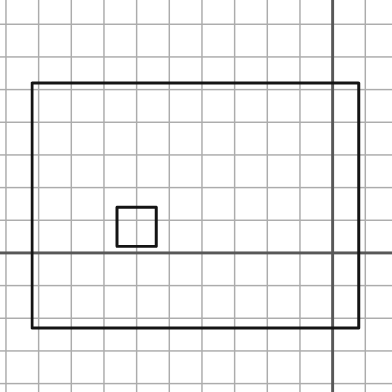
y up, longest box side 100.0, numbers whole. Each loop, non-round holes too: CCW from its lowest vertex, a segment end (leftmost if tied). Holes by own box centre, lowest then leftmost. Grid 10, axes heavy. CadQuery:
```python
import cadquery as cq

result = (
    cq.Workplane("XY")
    .moveTo(-92.0, -23.0)
    .lineTo(8.0, -23.0)
    .lineTo(8.0, 52.0)
    .lineTo(-92.0, 52.0)
    .close()
    .moveTo(-66.0, 2.0)
    .lineTo(-54.0, 2.0)
    .lineTo(-54.0, 14.0)
    .lineTo(-66.0, 14.0)
    .close()
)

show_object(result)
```